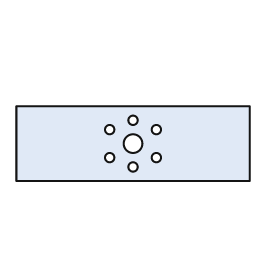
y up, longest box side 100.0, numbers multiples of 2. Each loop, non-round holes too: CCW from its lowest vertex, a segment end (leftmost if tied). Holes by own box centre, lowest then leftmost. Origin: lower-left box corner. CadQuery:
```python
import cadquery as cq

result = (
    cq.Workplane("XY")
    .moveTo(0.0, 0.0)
    .lineTo(100.0, 0.0)
    .lineTo(100.0, 32.0)
    .lineTo(0.0, 32.0)
    .close()
    .moveTo(50.0, 6.0)
    .circle(2.0)
    .moveTo(40.0, 10.0)
    .circle(2.0)
    .moveTo(60.0, 10.0)
    .circle(2.0)
    .moveTo(50.0, 16.0)
    .circle(4.0)
    .moveTo(40.0, 22.0)
    .circle(2.0)
    .moveTo(60.0, 22.0)
    .circle(2.0)
    .moveTo(50.0, 26.0)
    .circle(2.0)
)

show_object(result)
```